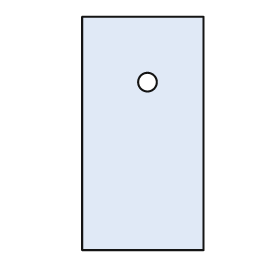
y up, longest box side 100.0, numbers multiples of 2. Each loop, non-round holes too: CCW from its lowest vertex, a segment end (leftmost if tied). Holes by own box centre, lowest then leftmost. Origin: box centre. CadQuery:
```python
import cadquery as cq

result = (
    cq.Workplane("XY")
    .moveTo(-26.0, -50.0)
    .lineTo(26.0, -50.0)
    .lineTo(26.0, 50.0)
    .lineTo(-26.0, 50.0)
    .close()
    .moveTo(2.0, 22.0)
    .circle(4.0)
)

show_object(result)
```